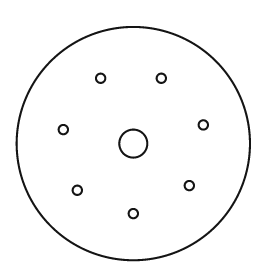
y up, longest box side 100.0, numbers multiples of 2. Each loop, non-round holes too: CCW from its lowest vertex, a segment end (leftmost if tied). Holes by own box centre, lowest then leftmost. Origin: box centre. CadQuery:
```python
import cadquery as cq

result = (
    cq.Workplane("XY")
    .moveTo(0.0, 0.0)
    .circle(50.0)
    .moveTo(0.0, -30.0)
    .circle(2.0)
    .moveTo(-24.0, -20.0)
    .circle(2.0)
    .moveTo(24.0, -18.0)
    .circle(2.0)
    .moveTo(0.0, 0.0)
    .circle(6.0)
    .moveTo(-30.0, 6.0)
    .circle(2.0)
    .moveTo(30.0, 8.0)
    .circle(2.0)
    .moveTo(-14.0, 28.0)
    .circle(2.0)
    .moveTo(12.0, 28.0)
    .circle(2.0)
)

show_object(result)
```